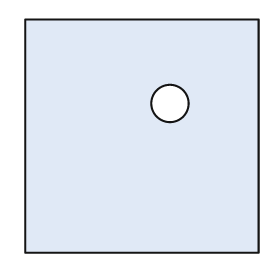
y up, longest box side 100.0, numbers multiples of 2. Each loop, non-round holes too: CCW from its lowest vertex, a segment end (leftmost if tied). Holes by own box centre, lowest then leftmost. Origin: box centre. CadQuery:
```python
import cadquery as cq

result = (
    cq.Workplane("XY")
    .moveTo(-50.0, -50.0)
    .lineTo(50.0, -50.0)
    .lineTo(50.0, 50.0)
    .lineTo(-50.0, 50.0)
    .close()
    .moveTo(12.0, 14.0)
    .circle(8.0)
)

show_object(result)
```